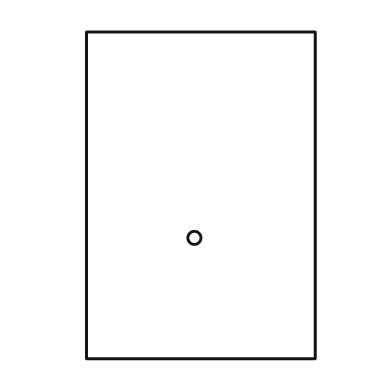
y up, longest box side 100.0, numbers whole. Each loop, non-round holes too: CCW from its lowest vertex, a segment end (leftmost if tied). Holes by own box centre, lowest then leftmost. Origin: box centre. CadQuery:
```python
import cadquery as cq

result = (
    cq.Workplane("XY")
    .moveTo(-35.0, -50.0)
    .lineTo(35.0, -50.0)
    .lineTo(35.0, 50.0)
    .lineTo(-35.0, 50.0)
    .close()
    .moveTo(-2.0, -13.0)
    .circle(2.0)
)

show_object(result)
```